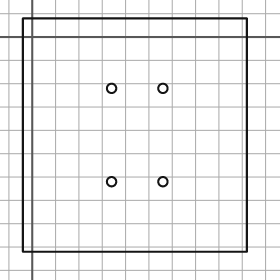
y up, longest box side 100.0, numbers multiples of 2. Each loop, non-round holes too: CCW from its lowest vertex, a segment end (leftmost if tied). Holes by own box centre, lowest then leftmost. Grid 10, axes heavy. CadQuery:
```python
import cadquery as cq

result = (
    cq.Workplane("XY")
    .moveTo(-4.0, -92.0)
    .lineTo(92.0, -92.0)
    .lineTo(92.0, 8.0)
    .lineTo(-4.0, 8.0)
    .close()
    .moveTo(34.0, -62.0)
    .circle(2.0)
    .moveTo(56.0, -62.0)
    .circle(2.0)
    .moveTo(34.0, -22.0)
    .circle(2.0)
    .moveTo(56.0, -22.0)
    .circle(2.0)
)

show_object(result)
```